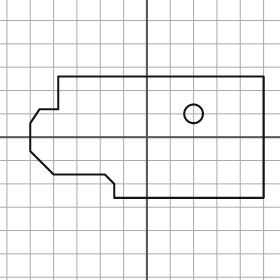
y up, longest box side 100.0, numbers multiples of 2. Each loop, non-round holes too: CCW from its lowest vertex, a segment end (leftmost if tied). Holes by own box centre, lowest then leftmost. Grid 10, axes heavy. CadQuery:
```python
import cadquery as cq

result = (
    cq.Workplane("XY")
    .moveTo(-14.0, -26.0)
    .lineTo(50.0, -26.0)
    .lineTo(50.0, 26.0)
    .lineTo(-38.0, 26.0)
    .lineTo(-38.0, 12.0)
    .lineTo(-46.0, 12.0)
    .lineTo(-50.0, 6.0)
    .lineTo(-50.0, -6.0)
    .lineTo(-40.0, -16.0)
    .lineTo(-18.0, -16.0)
    .lineTo(-14.0, -20.0)
    .close()
    .moveTo(20.0, 10.0)
    .circle(4.0)
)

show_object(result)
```